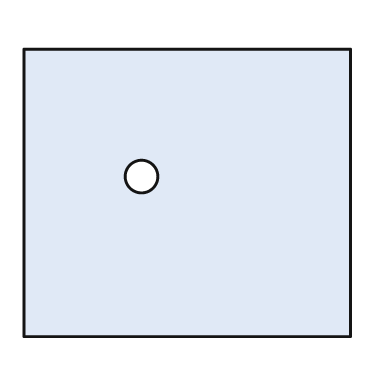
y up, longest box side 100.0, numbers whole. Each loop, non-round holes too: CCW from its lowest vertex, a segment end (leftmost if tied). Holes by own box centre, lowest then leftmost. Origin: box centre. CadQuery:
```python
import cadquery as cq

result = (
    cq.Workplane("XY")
    .moveTo(-50.0, -44.0)
    .lineTo(50.0, -44.0)
    .lineTo(50.0, 44.0)
    .lineTo(-50.0, 44.0)
    .close()
    .moveTo(-14.0, 5.0)
    .circle(5.0)
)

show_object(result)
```